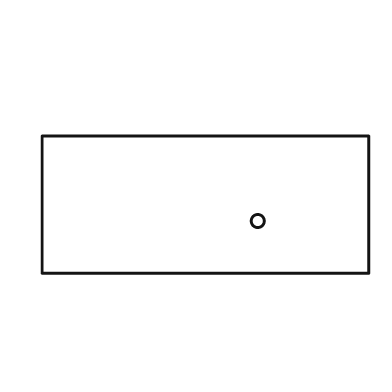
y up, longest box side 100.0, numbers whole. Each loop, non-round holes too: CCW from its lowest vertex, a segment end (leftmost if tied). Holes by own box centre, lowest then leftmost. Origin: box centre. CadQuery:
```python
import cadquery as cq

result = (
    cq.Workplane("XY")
    .moveTo(-50.0, -21.0)
    .lineTo(50.0, -21.0)
    .lineTo(50.0, 21.0)
    .lineTo(-50.0, 21.0)
    .close()
    .moveTo(16.0, -5.0)
    .circle(2.0)
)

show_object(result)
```